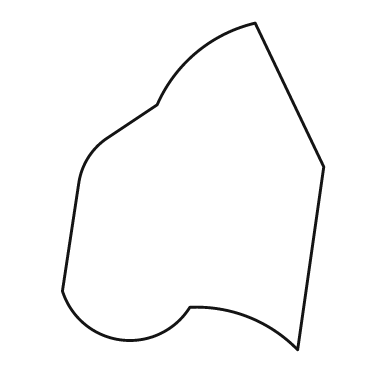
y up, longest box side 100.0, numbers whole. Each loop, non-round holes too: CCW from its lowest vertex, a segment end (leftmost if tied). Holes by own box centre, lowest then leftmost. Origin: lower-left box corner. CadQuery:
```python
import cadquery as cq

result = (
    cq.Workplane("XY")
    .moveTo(72.0, 0.0)
    .lineTo(80.0, 56.0)
    .lineTo(59.0, 100.0)
    .threePointArc((41.0, 91.0), (29.0, 75.0))
    .lineTo(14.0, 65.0)
    .threePointArc((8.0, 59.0), (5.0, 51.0))
    .lineTo(0.0, 18.0)
    .threePointArc((18.0, 3.0), (39.0, 13.0))
    .threePointArc((57.0, 10.0), (72.0, 0.0))
    .close()
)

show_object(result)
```